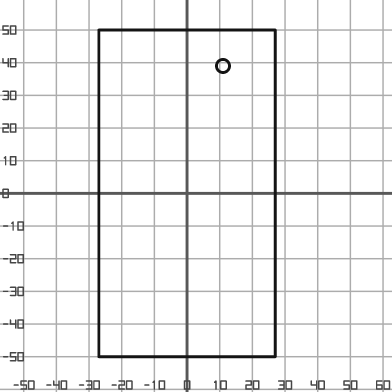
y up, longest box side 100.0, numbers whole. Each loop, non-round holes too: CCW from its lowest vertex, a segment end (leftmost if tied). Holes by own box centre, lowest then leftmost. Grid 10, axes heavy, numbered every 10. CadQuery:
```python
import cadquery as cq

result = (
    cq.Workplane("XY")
    .moveTo(-27.0, -50.0)
    .lineTo(27.0, -50.0)
    .lineTo(27.0, 50.0)
    .lineTo(-27.0, 50.0)
    .close()
    .moveTo(11.0, 39.0)
    .circle(2.0)
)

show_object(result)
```